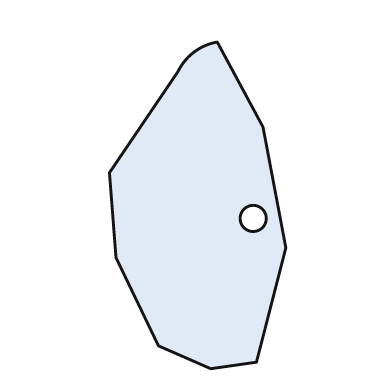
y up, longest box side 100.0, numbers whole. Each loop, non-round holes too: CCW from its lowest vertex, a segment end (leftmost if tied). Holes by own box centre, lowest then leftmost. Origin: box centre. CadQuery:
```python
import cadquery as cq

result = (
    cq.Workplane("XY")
    .moveTo(4.0, -50.0)
    .lineTo(18.0, -48.0)
    .lineTo(27.0, -13.0)
    .lineTo(20.0, 24.0)
    .lineTo(6.0, 50.0)
    .threePointArc((-1.0, 47.0), (-6.0, 41.0))
    .lineTo(-27.0, 10.0)
    .lineTo(-25.0, -16.0)
    .lineTo(-12.0, -43.0)
    .close()
    .moveTo(17.0, -4.0)
    .circle(4.0)
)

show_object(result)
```